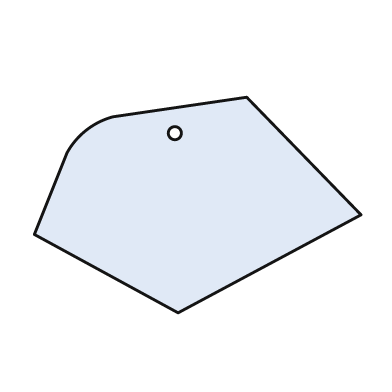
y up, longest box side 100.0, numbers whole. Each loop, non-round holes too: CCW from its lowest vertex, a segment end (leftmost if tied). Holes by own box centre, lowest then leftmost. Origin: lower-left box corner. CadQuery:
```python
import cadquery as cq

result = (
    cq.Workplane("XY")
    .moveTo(44.0, 0.0)
    .lineTo(100.0, 30.0)
    .lineTo(65.0, 66.0)
    .lineTo(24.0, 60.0)
    .threePointArc((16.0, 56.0), (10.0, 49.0))
    .lineTo(0.0, 24.0)
    .close()
    .moveTo(43.0, 55.0)
    .circle(2.0)
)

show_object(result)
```